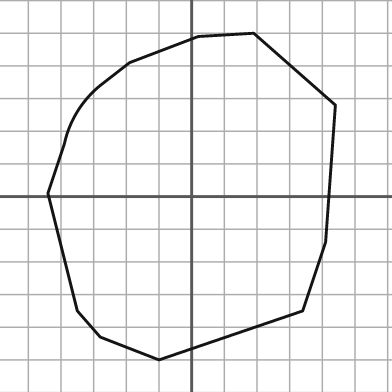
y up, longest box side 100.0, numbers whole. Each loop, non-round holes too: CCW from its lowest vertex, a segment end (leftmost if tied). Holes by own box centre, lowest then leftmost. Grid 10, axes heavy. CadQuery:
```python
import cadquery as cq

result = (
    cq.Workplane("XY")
    .moveTo(-10.0, -50.0)
    .lineTo(34.0, -35.0)
    .lineTo(41.0, -14.0)
    .lineTo(44.0, 28.0)
    .lineTo(19.0, 50.0)
    .lineTo(2.0, 49.0)
    .lineTo(-19.0, 41.0)
    .lineTo(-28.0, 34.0)
    .threePointArc((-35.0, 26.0), (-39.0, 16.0))
    .lineTo(-44.0, 1.0)
    .lineTo(-35.0, -35.0)
    .lineTo(-28.0, -43.0)
    .close()
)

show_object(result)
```